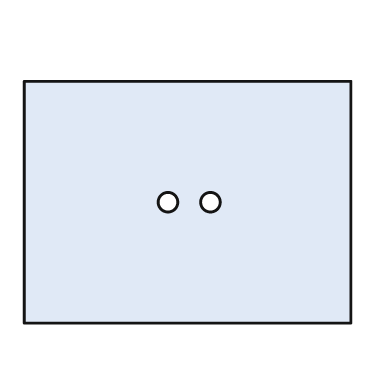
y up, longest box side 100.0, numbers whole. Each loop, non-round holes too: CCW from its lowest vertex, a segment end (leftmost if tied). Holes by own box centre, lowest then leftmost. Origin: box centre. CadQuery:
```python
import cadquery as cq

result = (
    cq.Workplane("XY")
    .moveTo(-50.0, -37.0)
    .lineTo(50.0, -37.0)
    .lineTo(50.0, 37.0)
    .lineTo(-50.0, 37.0)
    .close()
    .moveTo(-6.0, 0.0)
    .circle(3.0)
    .moveTo(7.0, 0.0)
    .circle(3.0)
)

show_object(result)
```